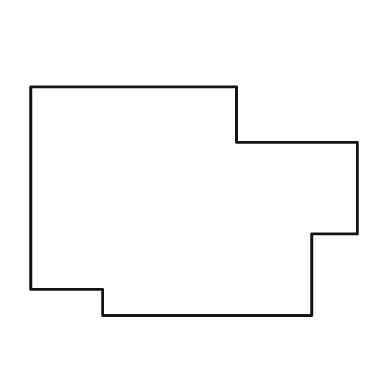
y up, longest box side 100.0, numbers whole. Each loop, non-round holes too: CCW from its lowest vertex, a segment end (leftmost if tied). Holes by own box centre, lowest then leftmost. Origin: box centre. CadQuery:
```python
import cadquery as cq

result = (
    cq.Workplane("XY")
    .moveTo(-28.0, -35.0)
    .lineTo(36.0, -35.0)
    .lineTo(36.0, -10.0)
    .lineTo(50.0, -10.0)
    .lineTo(50.0, 18.0)
    .lineTo(13.0, 18.0)
    .lineTo(13.0, 35.0)
    .lineTo(-50.0, 35.0)
    .lineTo(-50.0, -27.0)
    .lineTo(-28.0, -27.0)
    .close()
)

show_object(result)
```